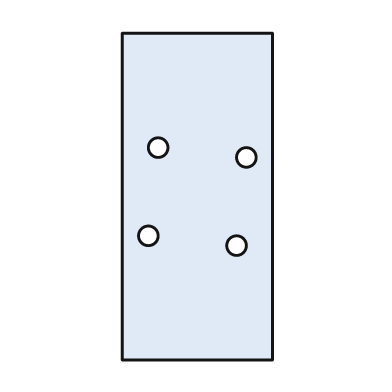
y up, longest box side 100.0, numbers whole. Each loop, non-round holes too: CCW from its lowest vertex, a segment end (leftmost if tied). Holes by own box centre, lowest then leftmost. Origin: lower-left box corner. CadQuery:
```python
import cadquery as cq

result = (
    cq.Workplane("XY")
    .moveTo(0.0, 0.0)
    .lineTo(46.0, 0.0)
    .lineTo(46.0, 100.0)
    .lineTo(0.0, 100.0)
    .close()
    .moveTo(35.0, 35.0)
    .circle(3.0)
    .moveTo(8.0, 38.0)
    .circle(3.0)
    .moveTo(38.0, 62.0)
    .circle(3.0)
    .moveTo(11.0, 65.0)
    .circle(3.0)
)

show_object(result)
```